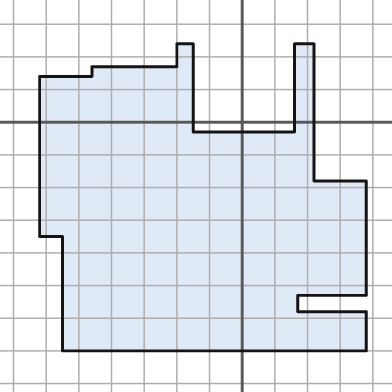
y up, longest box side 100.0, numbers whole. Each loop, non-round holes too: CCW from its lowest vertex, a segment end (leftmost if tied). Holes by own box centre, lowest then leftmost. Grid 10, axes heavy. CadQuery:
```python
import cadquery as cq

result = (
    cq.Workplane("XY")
    .moveTo(-55.0, -70.0)
    .lineTo(38.0, -70.0)
    .lineTo(38.0, -58.0)
    .lineTo(17.0, -58.0)
    .lineTo(17.0, -53.0)
    .lineTo(38.0, -53.0)
    .lineTo(38.0, -18.0)
    .lineTo(22.0, -18.0)
    .lineTo(22.0, 24.0)
    .lineTo(16.0, 24.0)
    .lineTo(16.0, -3.0)
    .lineTo(-15.0, -3.0)
    .lineTo(-15.0, 24.0)
    .lineTo(-20.0, 24.0)
    .lineTo(-20.0, 17.0)
    .lineTo(-46.0, 17.0)
    .lineTo(-46.0, 14.0)
    .lineTo(-62.0, 14.0)
    .lineTo(-62.0, -35.0)
    .lineTo(-55.0, -35.0)
    .close()
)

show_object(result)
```